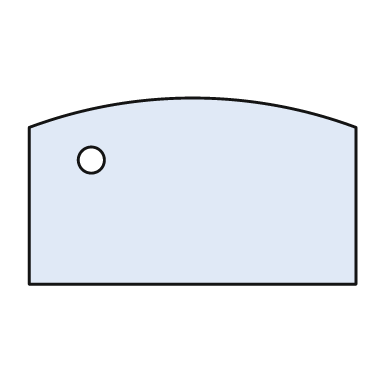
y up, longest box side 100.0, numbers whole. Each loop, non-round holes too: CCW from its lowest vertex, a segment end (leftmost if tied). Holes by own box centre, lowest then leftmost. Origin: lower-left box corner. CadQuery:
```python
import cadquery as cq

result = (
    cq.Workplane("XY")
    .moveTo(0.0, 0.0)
    .lineTo(100.0, 0.0)
    .lineTo(100.0, 48.0)
    .threePointArc((50.0, 57.0), (0.0, 48.0))
    .close()
    .moveTo(19.0, 38.0)
    .circle(4.0)
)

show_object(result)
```